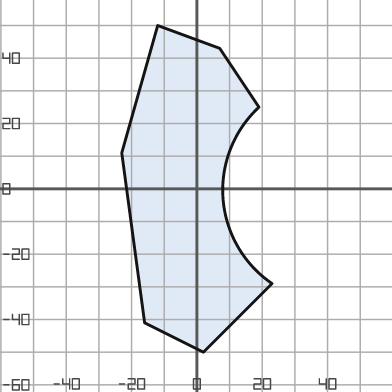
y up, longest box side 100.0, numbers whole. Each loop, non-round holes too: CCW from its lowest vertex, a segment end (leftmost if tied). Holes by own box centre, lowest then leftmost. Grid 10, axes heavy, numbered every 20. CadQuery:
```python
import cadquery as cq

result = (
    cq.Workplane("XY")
    .moveTo(2.0, -50.0)
    .lineTo(23.0, -29.0)
    .threePointArc((8.0, -3.0), (19.0, 25.0))
    .lineTo(7.0, 43.0)
    .lineTo(-12.0, 50.0)
    .lineTo(-23.0, 11.0)
    .lineTo(-16.0, -41.0)
    .close()
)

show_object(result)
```